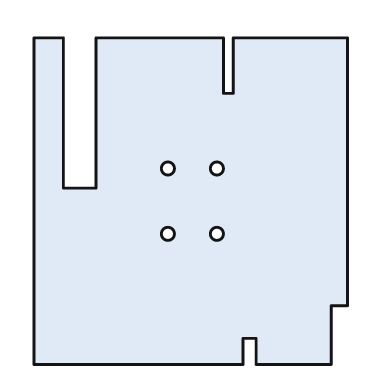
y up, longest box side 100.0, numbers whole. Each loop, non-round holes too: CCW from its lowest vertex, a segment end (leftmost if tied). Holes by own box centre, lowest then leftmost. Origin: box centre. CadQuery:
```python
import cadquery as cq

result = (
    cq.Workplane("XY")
    .moveTo(-48.0, -50.0)
    .lineTo(16.0, -50.0)
    .lineTo(16.0, -42.0)
    .lineTo(20.0, -42.0)
    .lineTo(20.0, -50.0)
    .lineTo(43.0, -50.0)
    .lineTo(43.0, -32.0)
    .lineTo(48.0, -32.0)
    .lineTo(48.0, 50.0)
    .lineTo(13.0, 50.0)
    .lineTo(13.0, 33.0)
    .lineTo(10.0, 33.0)
    .lineTo(10.0, 50.0)
    .lineTo(-29.0, 50.0)
    .lineTo(-29.0, 4.0)
    .lineTo(-39.0, 4.0)
    .lineTo(-39.0, 50.0)
    .lineTo(-48.0, 50.0)
    .close()
    .moveTo(-7.0, -10.0)
    .circle(2.0)
    .moveTo(8.0, -10.0)
    .circle(2.0)
    .moveTo(-7.0, 10.0)
    .circle(2.0)
    .moveTo(8.0, 10.0)
    .circle(2.0)
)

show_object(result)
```